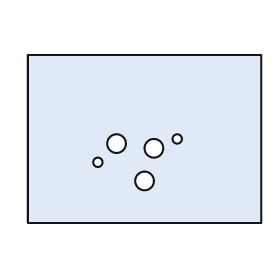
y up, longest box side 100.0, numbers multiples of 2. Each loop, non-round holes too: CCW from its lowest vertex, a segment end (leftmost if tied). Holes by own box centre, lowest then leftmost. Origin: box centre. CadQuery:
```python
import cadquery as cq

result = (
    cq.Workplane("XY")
    .moveTo(-50.0, -36.0)
    .lineTo(50.0, -36.0)
    .lineTo(50.0, 36.0)
    .lineTo(-50.0, 36.0)
    .close()
    .moveTo(0.0, -18.0)
    .circle(4.0)
    .moveTo(-20.0, -10.0)
    .circle(2.0)
    .moveTo(4.0, -4.0)
    .circle(4.0)
    .moveTo(-12.0, -2.0)
    .circle(4.0)
    .moveTo(14.0, 0.0)
    .circle(2.0)
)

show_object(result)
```